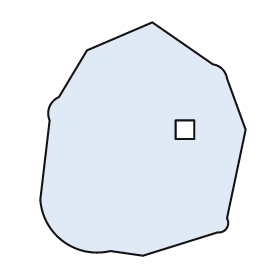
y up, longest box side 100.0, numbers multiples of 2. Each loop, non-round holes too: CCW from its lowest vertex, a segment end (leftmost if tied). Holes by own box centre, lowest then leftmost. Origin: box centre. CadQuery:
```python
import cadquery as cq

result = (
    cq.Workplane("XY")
    .moveTo(0.0, -50.0)
    .lineTo(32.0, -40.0)
    .threePointArc((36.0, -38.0), (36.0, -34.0))
    .lineTo(44.0, 4.0)
    .lineTo(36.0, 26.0)
    .threePointArc((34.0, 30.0), (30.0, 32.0))
    .lineTo(4.0, 50.0)
    .lineTo(-24.0, 38.0)
    .lineTo(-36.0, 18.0)
    .threePointArc((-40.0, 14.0), (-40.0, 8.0))
    .lineTo(-44.0, -26.0)
    .threePointArc((-34.0, -44.0), (-14.0, -48.0))
    .close()
    .moveTo(14.0, 0.0)
    .lineTo(22.0, 0.0)
    .lineTo(22.0, 8.0)
    .lineTo(14.0, 8.0)
    .close()
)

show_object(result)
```